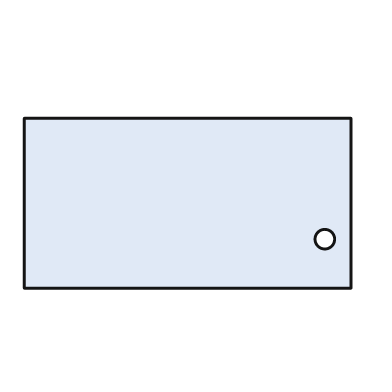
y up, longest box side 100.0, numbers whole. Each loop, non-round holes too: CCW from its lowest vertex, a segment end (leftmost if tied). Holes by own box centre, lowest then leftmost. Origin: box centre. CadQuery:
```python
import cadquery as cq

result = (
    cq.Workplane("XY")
    .moveTo(-50.0, -26.0)
    .lineTo(50.0, -26.0)
    .lineTo(50.0, 26.0)
    .lineTo(-50.0, 26.0)
    .close()
    .moveTo(42.0, -11.0)
    .circle(3.0)
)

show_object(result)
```